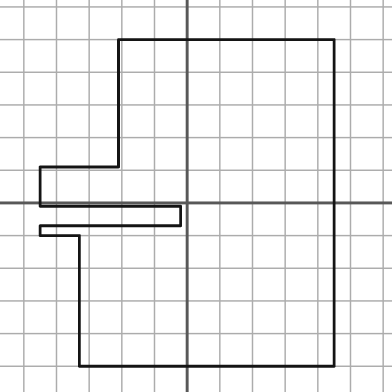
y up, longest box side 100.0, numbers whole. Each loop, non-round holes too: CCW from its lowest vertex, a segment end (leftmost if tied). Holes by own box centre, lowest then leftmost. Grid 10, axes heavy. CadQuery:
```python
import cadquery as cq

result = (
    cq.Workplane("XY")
    .moveTo(-33.0, -50.0)
    .lineTo(45.0, -50.0)
    .lineTo(45.0, 50.0)
    .lineTo(-21.0, 50.0)
    .lineTo(-21.0, 11.0)
    .lineTo(-45.0, 11.0)
    .lineTo(-45.0, -1.0)
    .lineTo(-2.0, -1.0)
    .lineTo(-2.0, -7.0)
    .lineTo(-45.0, -7.0)
    .lineTo(-45.0, -10.0)
    .lineTo(-33.0, -10.0)
    .close()
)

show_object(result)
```